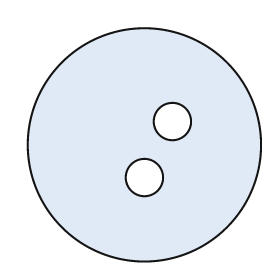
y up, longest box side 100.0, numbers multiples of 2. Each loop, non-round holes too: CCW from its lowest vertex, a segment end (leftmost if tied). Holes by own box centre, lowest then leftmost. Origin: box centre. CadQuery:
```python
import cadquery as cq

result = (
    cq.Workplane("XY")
    .moveTo(0.0, 0.0)
    .circle(50.0)
    .moveTo(0.0, -14.0)
    .circle(8.0)
    .moveTo(12.0, 10.0)
    .circle(8.0)
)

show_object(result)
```